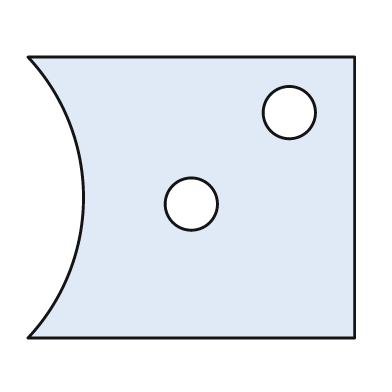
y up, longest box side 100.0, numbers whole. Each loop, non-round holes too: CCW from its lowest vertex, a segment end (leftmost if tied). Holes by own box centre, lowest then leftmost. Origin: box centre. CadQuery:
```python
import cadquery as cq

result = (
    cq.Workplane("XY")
    .moveTo(-50.0, -43.0)
    .lineTo(50.0, -43.0)
    .lineTo(50.0, 43.0)
    .lineTo(-50.0, 43.0)
    .threePointArc((-33.0, 0.0), (-50.0, -43.0))
    .close()
    .moveTo(0.0, -2.0)
    .circle(8.0)
    .moveTo(30.0, 26.0)
    .circle(8.0)
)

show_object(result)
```